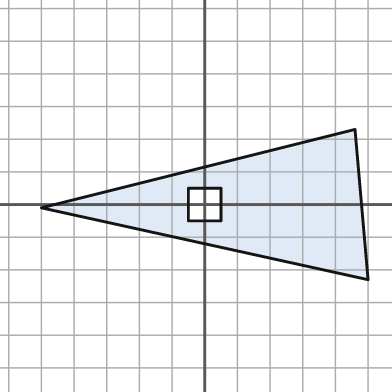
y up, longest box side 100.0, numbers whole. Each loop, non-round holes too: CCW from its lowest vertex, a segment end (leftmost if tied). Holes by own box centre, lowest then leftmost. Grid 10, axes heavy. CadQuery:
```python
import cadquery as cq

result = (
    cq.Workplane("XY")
    .moveTo(50.0, -23.0)
    .lineTo(46.0, 23.0)
    .lineTo(-50.0, -1.0)
    .close()
    .moveTo(-5.0, -5.0)
    .lineTo(5.0, -5.0)
    .lineTo(5.0, 5.0)
    .lineTo(-5.0, 5.0)
    .close()
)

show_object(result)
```